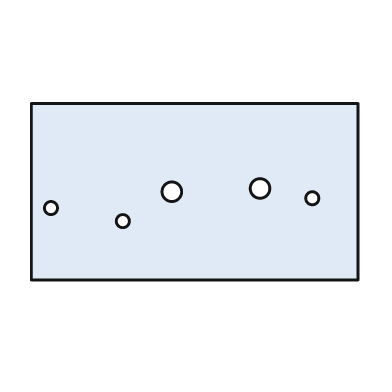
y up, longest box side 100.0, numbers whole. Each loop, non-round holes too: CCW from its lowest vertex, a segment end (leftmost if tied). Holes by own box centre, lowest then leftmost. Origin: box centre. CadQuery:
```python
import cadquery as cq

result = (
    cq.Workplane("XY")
    .moveTo(-50.0, -27.0)
    .lineTo(50.0, -27.0)
    .lineTo(50.0, 27.0)
    .lineTo(-50.0, 27.0)
    .close()
    .moveTo(-22.0, -9.0)
    .circle(2.0)
    .moveTo(-44.0, -5.0)
    .circle(2.0)
    .moveTo(36.0, -2.0)
    .circle(2.0)
    .moveTo(-7.0, 0.0)
    .circle(3.0)
    .moveTo(20.0, 1.0)
    .circle(3.0)
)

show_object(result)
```